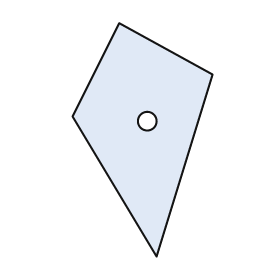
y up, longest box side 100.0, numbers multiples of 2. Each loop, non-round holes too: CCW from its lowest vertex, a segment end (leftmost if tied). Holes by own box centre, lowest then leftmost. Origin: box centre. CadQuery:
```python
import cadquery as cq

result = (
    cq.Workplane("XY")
    .moveTo(6.0, -50.0)
    .lineTo(30.0, 28.0)
    .lineTo(-10.0, 50.0)
    .lineTo(-30.0, 10.0)
    .close()
    .moveTo(2.0, 8.0)
    .circle(4.0)
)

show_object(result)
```